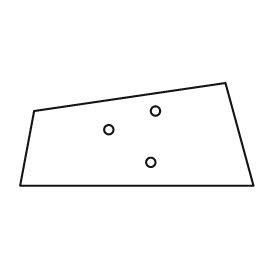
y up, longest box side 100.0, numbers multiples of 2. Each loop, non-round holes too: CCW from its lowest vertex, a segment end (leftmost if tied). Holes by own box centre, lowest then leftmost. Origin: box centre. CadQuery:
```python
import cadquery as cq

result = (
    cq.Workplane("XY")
    .moveTo(-50.0, -22.0)
    .lineTo(50.0, -22.0)
    .lineTo(38.0, 22.0)
    .lineTo(-44.0, 10.0)
    .close()
    .moveTo(6.0, -12.0)
    .circle(2.0)
    .moveTo(-12.0, 2.0)
    .circle(2.0)
    .moveTo(8.0, 10.0)
    .circle(2.0)
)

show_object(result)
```